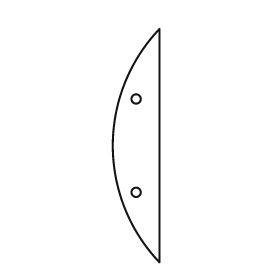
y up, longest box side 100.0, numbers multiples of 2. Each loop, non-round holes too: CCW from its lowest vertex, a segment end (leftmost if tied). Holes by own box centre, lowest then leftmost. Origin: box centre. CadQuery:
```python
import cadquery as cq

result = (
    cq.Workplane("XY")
    .moveTo(10.0, -50.0)
    .lineTo(10.0, 50.0)
    .threePointArc((-10.0, 0.0), (10.0, -50.0))
    .close()
    .moveTo(0.0, -20.0)
    .circle(2.0)
    .moveTo(0.0, 20.0)
    .circle(2.0)
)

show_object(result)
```